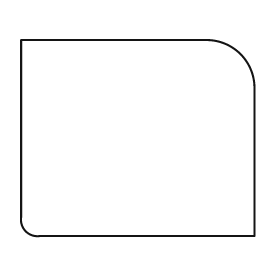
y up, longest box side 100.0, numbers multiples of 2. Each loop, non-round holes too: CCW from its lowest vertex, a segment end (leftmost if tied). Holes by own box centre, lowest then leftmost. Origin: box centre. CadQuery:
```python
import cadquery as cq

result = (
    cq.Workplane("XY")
    .moveTo(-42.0, -42.0)
    .lineTo(50.0, -42.0)
    .lineTo(50.0, 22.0)
    .threePointArc((44.0, 36.0), (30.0, 42.0))
    .lineTo(-50.0, 42.0)
    .lineTo(-50.0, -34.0)
    .threePointArc((-48.0, -40.0), (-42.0, -42.0))
    .close()
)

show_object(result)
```